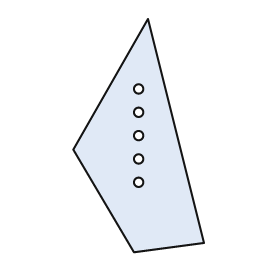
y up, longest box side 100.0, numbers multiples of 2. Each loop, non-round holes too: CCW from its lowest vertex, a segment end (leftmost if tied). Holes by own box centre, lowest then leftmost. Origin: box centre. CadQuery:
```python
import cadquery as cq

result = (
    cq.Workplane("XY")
    .moveTo(-2.0, -50.0)
    .lineTo(28.0, -46.0)
    .lineTo(4.0, 50.0)
    .lineTo(-28.0, -6.0)
    .close()
    .moveTo(0.0, -20.0)
    .circle(2.0)
    .moveTo(0.0, -10.0)
    .circle(2.0)
    .moveTo(0.0, 0.0)
    .circle(2.0)
    .moveTo(0.0, 10.0)
    .circle(2.0)
    .moveTo(0.0, 20.0)
    .circle(2.0)
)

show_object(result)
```